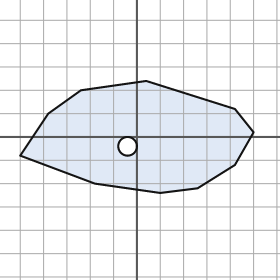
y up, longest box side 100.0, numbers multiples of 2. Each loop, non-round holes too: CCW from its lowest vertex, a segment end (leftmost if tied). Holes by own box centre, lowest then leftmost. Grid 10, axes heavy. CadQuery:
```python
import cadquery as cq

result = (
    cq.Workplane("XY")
    .moveTo(10.0, -24.0)
    .lineTo(26.0, -22.0)
    .lineTo(42.0, -12.0)
    .lineTo(50.0, 2.0)
    .lineTo(42.0, 12.0)
    .lineTo(4.0, 24.0)
    .lineTo(-24.0, 20.0)
    .lineTo(-38.0, 10.0)
    .lineTo(-50.0, -8.0)
    .lineTo(-18.0, -20.0)
    .close()
    .moveTo(-4.0, -4.0)
    .circle(4.0)
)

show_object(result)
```